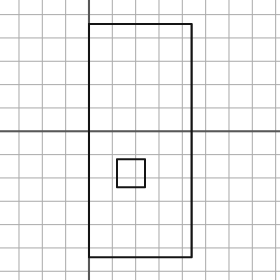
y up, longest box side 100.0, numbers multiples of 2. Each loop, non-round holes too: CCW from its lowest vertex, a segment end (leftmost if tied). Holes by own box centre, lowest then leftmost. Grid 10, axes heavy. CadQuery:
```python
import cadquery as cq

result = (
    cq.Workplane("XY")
    .moveTo(0.0, -54.0)
    .lineTo(44.0, -54.0)
    .lineTo(44.0, 46.0)
    .lineTo(0.0, 46.0)
    .close()
    .moveTo(12.0, -24.0)
    .lineTo(24.0, -24.0)
    .lineTo(24.0, -12.0)
    .lineTo(12.0, -12.0)
    .close()
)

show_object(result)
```